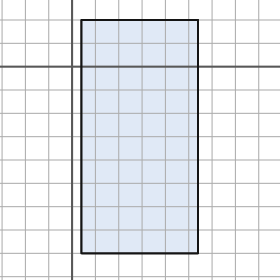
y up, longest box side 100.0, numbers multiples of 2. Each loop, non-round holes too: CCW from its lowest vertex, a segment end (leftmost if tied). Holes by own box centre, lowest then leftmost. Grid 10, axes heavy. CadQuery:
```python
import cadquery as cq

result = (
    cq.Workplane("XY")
    .moveTo(4.0, -80.0)
    .lineTo(54.0, -80.0)
    .lineTo(54.0, 20.0)
    .lineTo(4.0, 20.0)
    .close()
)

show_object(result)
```